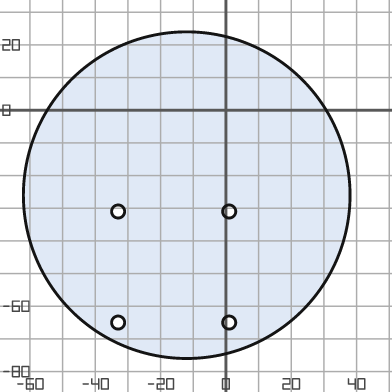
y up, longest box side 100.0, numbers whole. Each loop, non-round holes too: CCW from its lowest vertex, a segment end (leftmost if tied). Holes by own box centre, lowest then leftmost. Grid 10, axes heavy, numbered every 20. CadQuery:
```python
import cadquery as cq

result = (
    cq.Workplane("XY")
    .moveTo(-12.0, -26.0)
    .circle(50.0)
    .moveTo(-33.0, -65.0)
    .circle(2.0)
    .moveTo(1.0, -65.0)
    .circle(2.0)
    .moveTo(-33.0, -31.0)
    .circle(2.0)
    .moveTo(1.0, -31.0)
    .circle(2.0)
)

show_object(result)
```